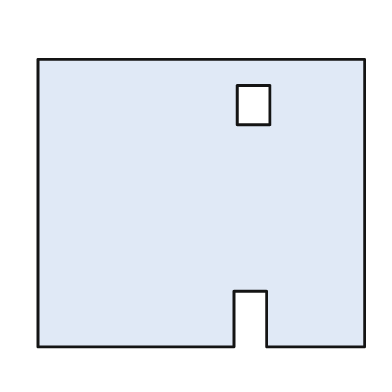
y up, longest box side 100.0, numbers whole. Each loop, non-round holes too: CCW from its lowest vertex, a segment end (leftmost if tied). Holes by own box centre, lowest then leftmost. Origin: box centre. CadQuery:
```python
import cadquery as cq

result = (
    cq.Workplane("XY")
    .moveTo(-50.0, -44.0)
    .lineTo(10.0, -44.0)
    .lineTo(10.0, -27.0)
    .lineTo(20.0, -27.0)
    .lineTo(20.0, -44.0)
    .lineTo(50.0, -44.0)
    .lineTo(50.0, 44.0)
    .lineTo(-50.0, 44.0)
    .close()
    .moveTo(11.0, 24.0)
    .lineTo(21.0, 24.0)
    .lineTo(21.0, 36.0)
    .lineTo(11.0, 36.0)
    .close()
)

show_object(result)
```